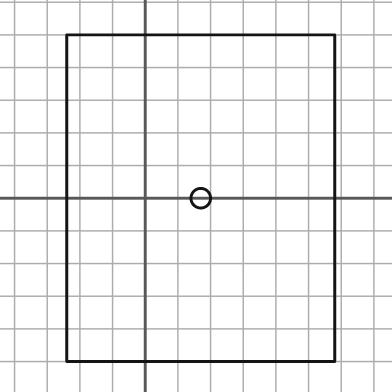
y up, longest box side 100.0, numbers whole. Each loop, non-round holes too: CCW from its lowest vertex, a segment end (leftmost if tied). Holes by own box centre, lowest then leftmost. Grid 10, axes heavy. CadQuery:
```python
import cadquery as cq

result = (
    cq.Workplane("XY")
    .moveTo(-24.0, -50.0)
    .lineTo(58.0, -50.0)
    .lineTo(58.0, 50.0)
    .lineTo(-24.0, 50.0)
    .close()
    .moveTo(17.0, 0.0)
    .circle(3.0)
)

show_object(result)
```